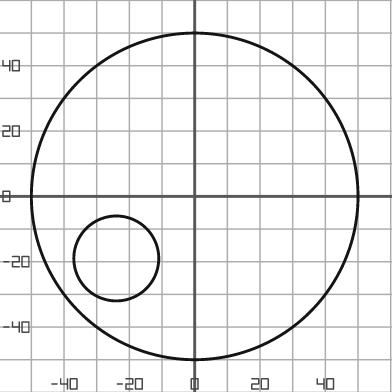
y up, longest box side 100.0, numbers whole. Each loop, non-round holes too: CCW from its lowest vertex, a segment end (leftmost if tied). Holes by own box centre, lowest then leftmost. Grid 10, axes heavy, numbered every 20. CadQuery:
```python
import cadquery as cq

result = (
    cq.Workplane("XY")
    .moveTo(0.0, 0.0)
    .circle(50.0)
    .moveTo(-24.0, -19.0)
    .circle(13.0)
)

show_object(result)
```